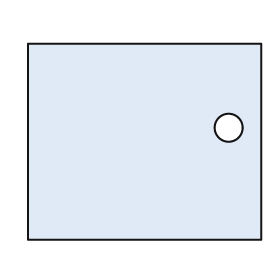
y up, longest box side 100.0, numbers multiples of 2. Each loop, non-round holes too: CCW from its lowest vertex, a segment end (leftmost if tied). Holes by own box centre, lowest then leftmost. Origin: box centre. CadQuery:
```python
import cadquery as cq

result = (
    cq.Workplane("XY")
    .moveTo(-50.0, -42.0)
    .lineTo(50.0, -42.0)
    .lineTo(50.0, 42.0)
    .lineTo(-50.0, 42.0)
    .close()
    .moveTo(36.0, 6.0)
    .circle(6.0)
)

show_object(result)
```